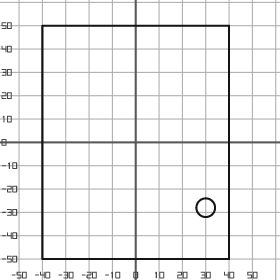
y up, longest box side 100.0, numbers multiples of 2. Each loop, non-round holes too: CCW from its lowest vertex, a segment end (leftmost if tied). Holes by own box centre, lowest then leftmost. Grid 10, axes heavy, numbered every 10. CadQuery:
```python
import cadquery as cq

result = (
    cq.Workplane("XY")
    .moveTo(-40.0, -50.0)
    .lineTo(40.0, -50.0)
    .lineTo(40.0, 50.0)
    .lineTo(-40.0, 50.0)
    .close()
    .moveTo(30.0, -28.0)
    .circle(4.0)
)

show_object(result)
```